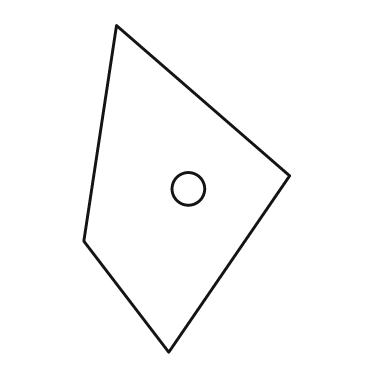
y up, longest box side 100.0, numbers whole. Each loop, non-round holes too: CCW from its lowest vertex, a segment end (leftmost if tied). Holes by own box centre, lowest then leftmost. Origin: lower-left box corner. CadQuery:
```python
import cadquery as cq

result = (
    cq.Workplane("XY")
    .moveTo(26.0, 0.0)
    .lineTo(63.0, 54.0)
    .lineTo(10.0, 100.0)
    .lineTo(0.0, 34.0)
    .close()
    .moveTo(32.0, 50.0)
    .circle(5.0)
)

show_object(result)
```